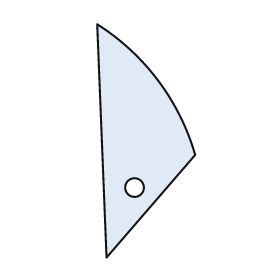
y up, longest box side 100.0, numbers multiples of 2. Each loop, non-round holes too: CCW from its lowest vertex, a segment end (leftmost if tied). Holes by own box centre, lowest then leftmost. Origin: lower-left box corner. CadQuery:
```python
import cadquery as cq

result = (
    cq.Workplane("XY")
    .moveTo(4.0, 0.0)
    .lineTo(42.0, 44.0)
    .threePointArc((26.0, 76.0), (0.0, 100.0))
    .close()
    .moveTo(16.0, 30.0)
    .circle(4.0)
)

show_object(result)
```